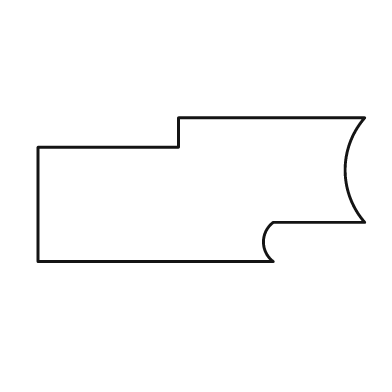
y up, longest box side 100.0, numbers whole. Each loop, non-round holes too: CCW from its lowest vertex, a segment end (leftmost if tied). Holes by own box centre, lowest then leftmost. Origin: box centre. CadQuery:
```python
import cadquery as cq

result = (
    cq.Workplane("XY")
    .moveTo(-50.0, -22.0)
    .lineTo(22.0, -22.0)
    .threePointArc((19.0, -16.0), (22.0, -10.0))
    .lineTo(50.0, -10.0)
    .threePointArc((44.0, 6.0), (50.0, 22.0))
    .lineTo(-7.0, 22.0)
    .lineTo(-7.0, 13.0)
    .lineTo(-50.0, 13.0)
    .close()
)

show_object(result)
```